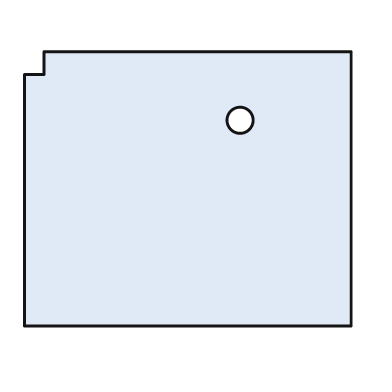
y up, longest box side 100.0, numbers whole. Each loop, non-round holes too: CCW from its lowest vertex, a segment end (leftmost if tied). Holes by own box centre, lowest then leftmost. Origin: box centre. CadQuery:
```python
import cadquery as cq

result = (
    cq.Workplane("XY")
    .moveTo(-50.0, -42.0)
    .lineTo(50.0, -42.0)
    .lineTo(50.0, 42.0)
    .lineTo(-44.0, 42.0)
    .lineTo(-44.0, 35.0)
    .lineTo(-50.0, 35.0)
    .close()
    .moveTo(16.0, 21.0)
    .circle(4.0)
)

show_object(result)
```